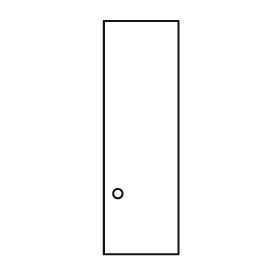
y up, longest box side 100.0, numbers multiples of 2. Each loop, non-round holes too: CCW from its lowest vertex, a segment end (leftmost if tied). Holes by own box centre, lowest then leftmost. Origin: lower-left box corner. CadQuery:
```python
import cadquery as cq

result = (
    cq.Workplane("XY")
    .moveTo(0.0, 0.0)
    .lineTo(32.0, 0.0)
    .lineTo(32.0, 100.0)
    .lineTo(0.0, 100.0)
    .close()
    .moveTo(6.0, 26.0)
    .circle(2.0)
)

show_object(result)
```